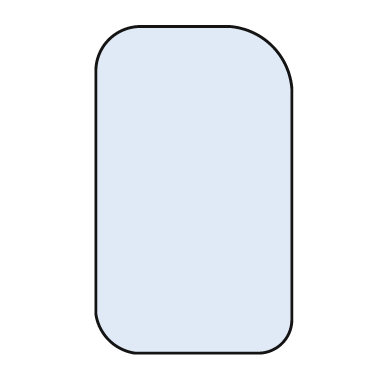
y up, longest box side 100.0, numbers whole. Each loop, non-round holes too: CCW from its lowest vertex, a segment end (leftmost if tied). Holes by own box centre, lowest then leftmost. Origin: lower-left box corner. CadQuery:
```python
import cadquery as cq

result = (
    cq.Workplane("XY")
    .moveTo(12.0, 0.0)
    .lineTo(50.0, 0.0)
    .threePointArc((57.0, 3.0), (60.0, 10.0))
    .lineTo(60.0, 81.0)
    .threePointArc((54.0, 94.0), (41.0, 100.0))
    .lineTo(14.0, 100.0)
    .threePointArc((4.0, 96.0), (0.0, 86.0))
    .lineTo(0.0, 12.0)
    .threePointArc((4.0, 4.0), (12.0, 0.0))
    .close()
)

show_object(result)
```